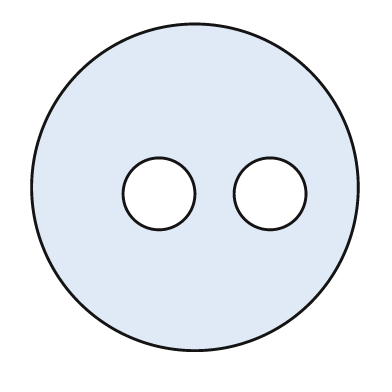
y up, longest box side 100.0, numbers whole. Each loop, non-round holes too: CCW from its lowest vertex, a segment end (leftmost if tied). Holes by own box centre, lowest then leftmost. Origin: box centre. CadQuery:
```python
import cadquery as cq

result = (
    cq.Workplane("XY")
    .moveTo(0.0, 0.0)
    .circle(50.0)
    .moveTo(-11.0, -2.0)
    .circle(11.0)
    .moveTo(23.0, -2.0)
    .circle(11.0)
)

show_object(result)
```